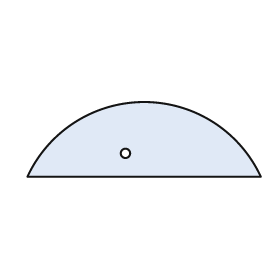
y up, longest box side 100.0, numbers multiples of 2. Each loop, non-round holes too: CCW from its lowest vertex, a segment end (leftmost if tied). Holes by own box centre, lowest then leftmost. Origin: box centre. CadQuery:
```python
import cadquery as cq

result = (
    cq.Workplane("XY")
    .moveTo(-50.0, -16.0)
    .lineTo(50.0, -16.0)
    .threePointArc((0.0, 16.0), (-50.0, -16.0))
    .close()
    .moveTo(-8.0, -6.0)
    .circle(2.0)
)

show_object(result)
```